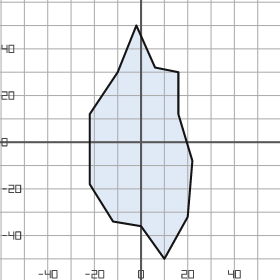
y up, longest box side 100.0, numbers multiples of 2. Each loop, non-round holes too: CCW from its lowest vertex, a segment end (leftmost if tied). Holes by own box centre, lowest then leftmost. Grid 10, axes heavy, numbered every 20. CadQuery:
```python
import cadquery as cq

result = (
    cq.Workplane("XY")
    .moveTo(10.0, -50.0)
    .lineTo(20.0, -32.0)
    .lineTo(22.0, -8.0)
    .lineTo(16.0, 12.0)
    .lineTo(16.0, 30.0)
    .lineTo(6.0, 32.0)
    .lineTo(-2.0, 50.0)
    .lineTo(-10.0, 30.0)
    .lineTo(-22.0, 12.0)
    .lineTo(-22.0, -18.0)
    .lineTo(-12.0, -34.0)
    .lineTo(0.0, -36.0)
    .close()
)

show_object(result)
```